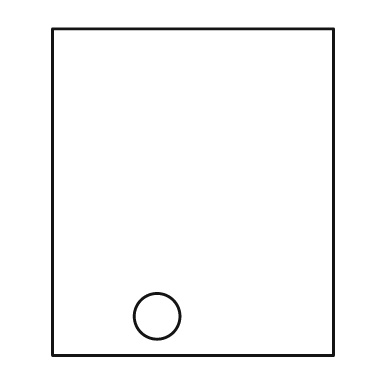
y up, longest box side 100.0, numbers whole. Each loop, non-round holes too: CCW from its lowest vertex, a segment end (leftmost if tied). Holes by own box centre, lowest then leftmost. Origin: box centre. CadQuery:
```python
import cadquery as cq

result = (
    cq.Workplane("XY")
    .moveTo(-43.0, -50.0)
    .lineTo(43.0, -50.0)
    .lineTo(43.0, 50.0)
    .lineTo(-43.0, 50.0)
    .close()
    .moveTo(-11.0, -38.0)
    .circle(7.0)
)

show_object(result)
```